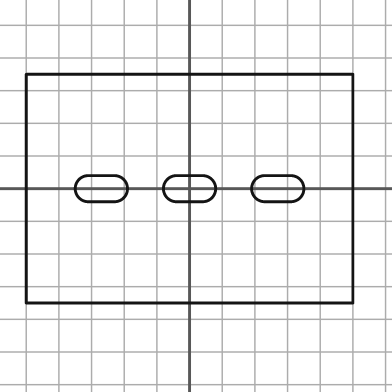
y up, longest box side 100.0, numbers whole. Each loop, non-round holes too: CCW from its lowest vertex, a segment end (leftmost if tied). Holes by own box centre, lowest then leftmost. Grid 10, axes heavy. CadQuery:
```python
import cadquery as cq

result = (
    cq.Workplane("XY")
    .moveTo(-50.0, -35.0)
    .lineTo(50.0, -35.0)
    .lineTo(50.0, 35.0)
    .lineTo(-50.0, 35.0)
    .close()
    .moveTo(-31.0, -4.0)
    .lineTo(-23.0, -4.0)
    .threePointArc((-19.0, 0.0), (-23.0, 4.0))
    .lineTo(-31.0, 4.0)
    .threePointArc((-35.0, 0.0), (-31.0, -4.0))
    .close()
    .moveTo(-4.0, -4.0)
    .lineTo(4.0, -4.0)
    .threePointArc((8.0, 0.0), (4.0, 4.0))
    .lineTo(-4.0, 4.0)
    .threePointArc((-8.0, 0.0), (-4.0, -4.0))
    .close()
    .moveTo(23.0, -4.0)
    .lineTo(31.0, -4.0)
    .threePointArc((35.0, 0.0), (31.0, 4.0))
    .lineTo(23.0, 4.0)
    .threePointArc((19.0, 0.0), (23.0, -4.0))
    .close()
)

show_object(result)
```